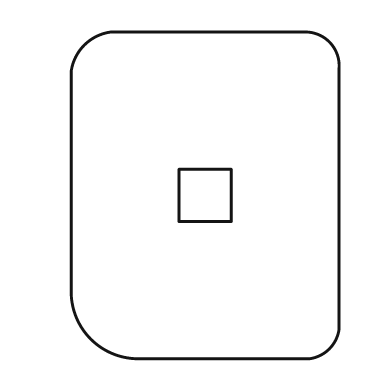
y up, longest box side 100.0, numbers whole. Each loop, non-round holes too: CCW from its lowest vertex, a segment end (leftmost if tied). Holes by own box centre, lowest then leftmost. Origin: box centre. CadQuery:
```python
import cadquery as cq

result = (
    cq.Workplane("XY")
    .moveTo(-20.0, -50.0)
    .lineTo(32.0, -50.0)
    .threePointArc((38.0, -47.0), (41.0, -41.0))
    .lineTo(41.0, 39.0)
    .threePointArc((38.0, 47.0), (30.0, 50.0))
    .lineTo(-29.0, 50.0)
    .threePointArc((-37.0, 46.0), (-41.0, 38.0))
    .lineTo(-41.0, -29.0)
    .threePointArc((-35.0, -44.0), (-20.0, -50.0))
    .close()
    .moveTo(-8.0, -8.0)
    .lineTo(8.0, -8.0)
    .lineTo(8.0, 8.0)
    .lineTo(-8.0, 8.0)
    .close()
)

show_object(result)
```